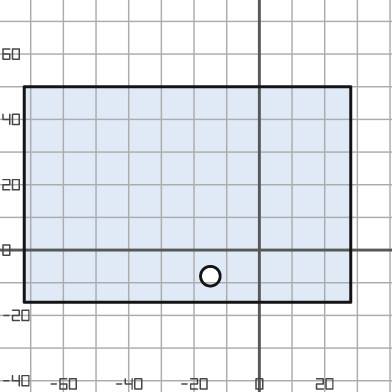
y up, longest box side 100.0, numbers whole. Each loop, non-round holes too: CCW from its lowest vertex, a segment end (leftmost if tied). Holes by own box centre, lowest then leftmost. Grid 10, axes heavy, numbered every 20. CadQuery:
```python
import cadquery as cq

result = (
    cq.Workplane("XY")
    .moveTo(-72.0, -16.0)
    .lineTo(28.0, -16.0)
    .lineTo(28.0, 50.0)
    .lineTo(-72.0, 50.0)
    .close()
    .moveTo(-15.0, -8.0)
    .circle(3.0)
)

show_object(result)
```